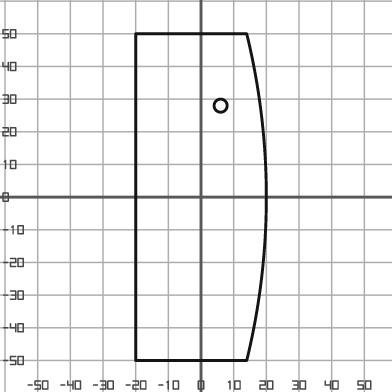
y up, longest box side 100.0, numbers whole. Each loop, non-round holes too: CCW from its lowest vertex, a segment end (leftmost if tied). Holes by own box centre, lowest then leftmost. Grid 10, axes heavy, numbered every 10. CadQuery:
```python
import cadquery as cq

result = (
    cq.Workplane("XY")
    .moveTo(-20.0, -50.0)
    .lineTo(14.0, -50.0)
    .threePointArc((20.0, 0.0), (14.0, 50.0))
    .lineTo(-20.0, 50.0)
    .close()
    .moveTo(6.0, 28.0)
    .circle(2.0)
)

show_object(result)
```